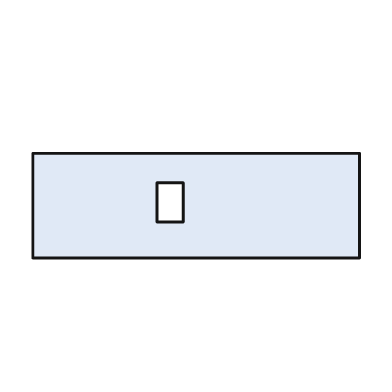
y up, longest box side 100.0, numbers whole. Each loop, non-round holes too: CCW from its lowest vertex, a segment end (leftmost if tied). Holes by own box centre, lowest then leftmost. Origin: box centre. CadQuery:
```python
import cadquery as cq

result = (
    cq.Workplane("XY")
    .moveTo(-50.0, -16.0)
    .lineTo(50.0, -16.0)
    .lineTo(50.0, 16.0)
    .lineTo(-50.0, 16.0)
    .close()
    .moveTo(-12.0, -5.0)
    .lineTo(-4.0, -5.0)
    .lineTo(-4.0, 7.0)
    .lineTo(-12.0, 7.0)
    .close()
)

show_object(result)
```